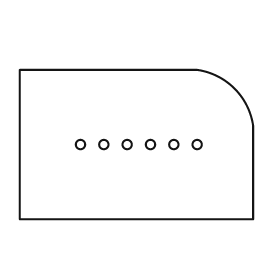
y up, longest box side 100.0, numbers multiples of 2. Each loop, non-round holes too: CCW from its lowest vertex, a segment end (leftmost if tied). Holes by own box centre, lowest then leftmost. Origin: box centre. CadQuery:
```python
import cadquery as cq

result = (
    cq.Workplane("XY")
    .moveTo(-50.0, -32.0)
    .lineTo(50.0, -32.0)
    .lineTo(50.0, 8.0)
    .threePointArc((42.0, 24.0), (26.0, 32.0))
    .lineTo(-50.0, 32.0)
    .close()
    .moveTo(-24.0, 0.0)
    .circle(2.0)
    .moveTo(-14.0, 0.0)
    .circle(2.0)
    .moveTo(-4.0, 0.0)
    .circle(2.0)
    .moveTo(6.0, 0.0)
    .circle(2.0)
    .moveTo(16.0, 0.0)
    .circle(2.0)
    .moveTo(26.0, 0.0)
    .circle(2.0)
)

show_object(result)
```